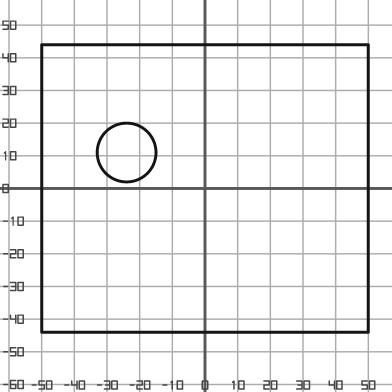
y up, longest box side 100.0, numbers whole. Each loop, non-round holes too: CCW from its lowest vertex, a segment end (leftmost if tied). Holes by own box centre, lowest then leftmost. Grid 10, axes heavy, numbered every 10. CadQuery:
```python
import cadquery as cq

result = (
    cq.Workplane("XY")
    .moveTo(-50.0, -44.0)
    .lineTo(50.0, -44.0)
    .lineTo(50.0, 44.0)
    .lineTo(-50.0, 44.0)
    .close()
    .moveTo(-24.0, 11.0)
    .circle(9.0)
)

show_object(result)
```